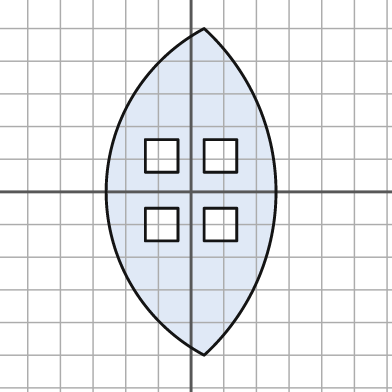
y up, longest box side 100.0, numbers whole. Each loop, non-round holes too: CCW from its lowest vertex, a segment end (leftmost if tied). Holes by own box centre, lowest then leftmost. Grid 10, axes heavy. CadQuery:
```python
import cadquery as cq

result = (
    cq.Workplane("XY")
    .moveTo(4.0, -50.0)
    .threePointArc((26.0, 0.0), (4.0, 50.0))
    .threePointArc((-26.0, 0.0), (4.0, -50.0))
    .close()
    .moveTo(-14.0, -15.0)
    .lineTo(-4.0, -15.0)
    .lineTo(-4.0, -5.0)
    .lineTo(-14.0, -5.0)
    .close()
    .moveTo(4.0, -15.0)
    .lineTo(14.0, -15.0)
    .lineTo(14.0, -5.0)
    .lineTo(4.0, -5.0)
    .close()
    .moveTo(-14.0, 6.0)
    .lineTo(-4.0, 6.0)
    .lineTo(-4.0, 16.0)
    .lineTo(-14.0, 16.0)
    .close()
    .moveTo(4.0, 6.0)
    .lineTo(14.0, 6.0)
    .lineTo(14.0, 16.0)
    .lineTo(4.0, 16.0)
    .close()
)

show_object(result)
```